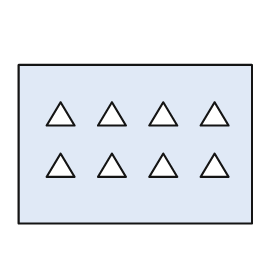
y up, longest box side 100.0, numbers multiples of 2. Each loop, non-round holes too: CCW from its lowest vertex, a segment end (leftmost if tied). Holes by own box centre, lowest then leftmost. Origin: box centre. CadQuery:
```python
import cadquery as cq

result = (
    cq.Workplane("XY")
    .moveTo(-50.0, -34.0)
    .lineTo(50.0, -34.0)
    .lineTo(50.0, 34.0)
    .lineTo(-50.0, 34.0)
    .close()
    .moveTo(-38.0, -14.0)
    .lineTo(-26.0, -14.0)
    .lineTo(-32.0, -4.0)
    .close()
    .moveTo(-16.0, -14.0)
    .lineTo(-4.0, -14.0)
    .lineTo(-10.0, -4.0)
    .close()
    .moveTo(6.0, -14.0)
    .lineTo(18.0, -14.0)
    .lineTo(12.0, -4.0)
    .close()
    .moveTo(28.0, -14.0)
    .lineTo(40.0, -14.0)
    .lineTo(34.0, -4.0)
    .close()
    .moveTo(-38.0, 8.0)
    .lineTo(-26.0, 8.0)
    .lineTo(-32.0, 18.0)
    .close()
    .moveTo(-16.0, 8.0)
    .lineTo(-4.0, 8.0)
    .lineTo(-10.0, 18.0)
    .close()
    .moveTo(6.0, 8.0)
    .lineTo(18.0, 8.0)
    .lineTo(12.0, 18.0)
    .close()
    .moveTo(28.0, 8.0)
    .lineTo(40.0, 8.0)
    .lineTo(34.0, 18.0)
    .close()
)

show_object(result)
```